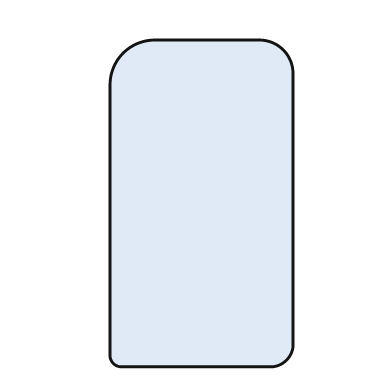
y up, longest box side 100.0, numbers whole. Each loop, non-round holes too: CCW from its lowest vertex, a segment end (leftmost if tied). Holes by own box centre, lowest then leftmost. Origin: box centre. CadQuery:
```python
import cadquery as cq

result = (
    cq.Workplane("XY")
    .moveTo(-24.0, -50.0)
    .lineTo(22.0, -50.0)
    .threePointArc((26.0, -48.0), (28.0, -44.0))
    .lineTo(28.0, 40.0)
    .threePointArc((25.0, 47.0), (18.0, 50.0))
    .lineTo(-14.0, 50.0)
    .threePointArc((-24.0, 46.0), (-28.0, 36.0))
    .lineTo(-28.0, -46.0)
    .threePointArc((-27.0, -49.0), (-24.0, -50.0))
    .close()
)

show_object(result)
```